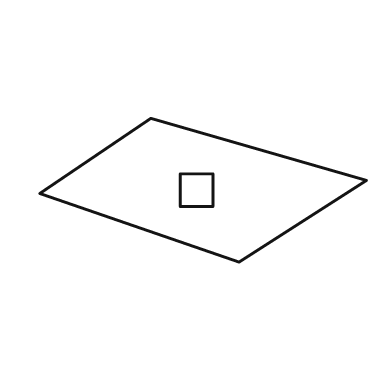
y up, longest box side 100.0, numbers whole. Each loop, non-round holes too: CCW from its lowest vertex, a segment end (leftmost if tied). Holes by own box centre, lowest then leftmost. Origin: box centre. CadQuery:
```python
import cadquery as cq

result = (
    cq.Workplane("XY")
    .moveTo(11.0, -22.0)
    .lineTo(50.0, 3.0)
    .lineTo(-16.0, 22.0)
    .lineTo(-50.0, -1.0)
    .close()
    .moveTo(-7.0, -5.0)
    .lineTo(3.0, -5.0)
    .lineTo(3.0, 5.0)
    .lineTo(-7.0, 5.0)
    .close()
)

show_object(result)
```